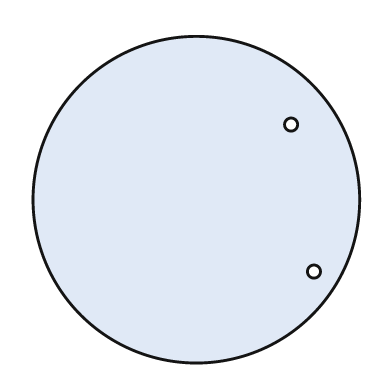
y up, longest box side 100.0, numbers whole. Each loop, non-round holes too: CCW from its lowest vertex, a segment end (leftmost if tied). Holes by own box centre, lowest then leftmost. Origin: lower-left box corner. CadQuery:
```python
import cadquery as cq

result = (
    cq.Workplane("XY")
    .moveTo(50.0, 50.0)
    .circle(50.0)
    .moveTo(86.0, 28.0)
    .circle(2.0)
    .moveTo(79.0, 73.0)
    .circle(2.0)
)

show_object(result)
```